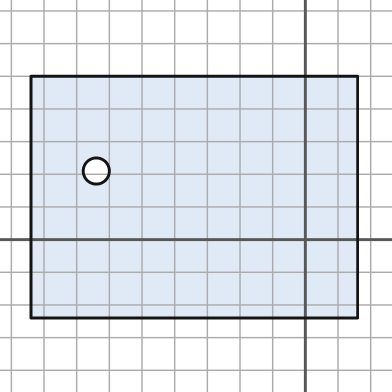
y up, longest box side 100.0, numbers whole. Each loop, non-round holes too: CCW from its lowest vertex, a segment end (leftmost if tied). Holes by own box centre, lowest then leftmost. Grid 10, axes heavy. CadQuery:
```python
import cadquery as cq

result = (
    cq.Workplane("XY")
    .moveTo(-84.0, -24.0)
    .lineTo(16.0, -24.0)
    .lineTo(16.0, 50.0)
    .lineTo(-84.0, 50.0)
    .close()
    .moveTo(-64.0, 21.0)
    .circle(4.0)
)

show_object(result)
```